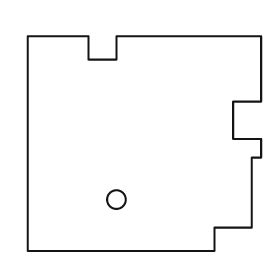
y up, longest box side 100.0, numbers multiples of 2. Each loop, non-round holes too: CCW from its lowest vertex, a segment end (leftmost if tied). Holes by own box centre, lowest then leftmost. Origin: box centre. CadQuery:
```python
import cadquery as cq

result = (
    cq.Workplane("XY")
    .moveTo(-50.0, -46.0)
    .lineTo(30.0, -46.0)
    .lineTo(30.0, -36.0)
    .lineTo(46.0, -36.0)
    .lineTo(46.0, -6.0)
    .lineTo(50.0, -6.0)
    .lineTo(50.0, 2.0)
    .lineTo(38.0, 2.0)
    .lineTo(38.0, 18.0)
    .lineTo(50.0, 18.0)
    .lineTo(50.0, 46.0)
    .lineTo(-12.0, 46.0)
    .lineTo(-12.0, 36.0)
    .lineTo(-24.0, 36.0)
    .lineTo(-24.0, 46.0)
    .lineTo(-50.0, 46.0)
    .close()
    .moveTo(-12.0, -24.0)
    .circle(4.0)
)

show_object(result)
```